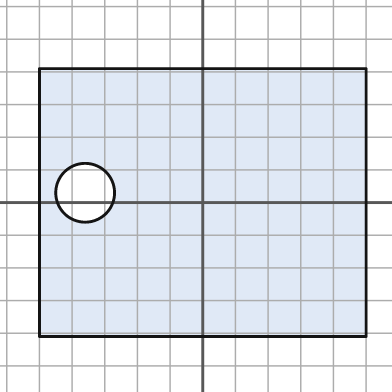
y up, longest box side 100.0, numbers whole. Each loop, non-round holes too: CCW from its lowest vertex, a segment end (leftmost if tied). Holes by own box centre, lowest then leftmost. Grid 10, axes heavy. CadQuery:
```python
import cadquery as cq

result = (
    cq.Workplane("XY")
    .moveTo(-50.0, -41.0)
    .lineTo(50.0, -41.0)
    .lineTo(50.0, 41.0)
    .lineTo(-50.0, 41.0)
    .close()
    .moveTo(-36.0, 3.0)
    .circle(9.0)
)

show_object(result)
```